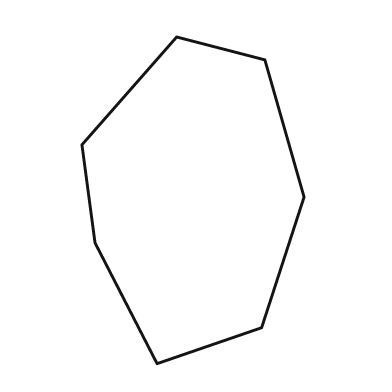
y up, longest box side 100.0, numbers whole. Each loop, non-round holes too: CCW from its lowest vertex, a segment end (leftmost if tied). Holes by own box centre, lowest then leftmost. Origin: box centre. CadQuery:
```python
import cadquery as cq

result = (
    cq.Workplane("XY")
    .moveTo(-11.0, -50.0)
    .lineTo(21.0, -39.0)
    .lineTo(34.0, 1.0)
    .lineTo(22.0, 43.0)
    .lineTo(-5.0, 50.0)
    .lineTo(-34.0, 17.0)
    .lineTo(-30.0, -13.0)
    .close()
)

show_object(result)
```